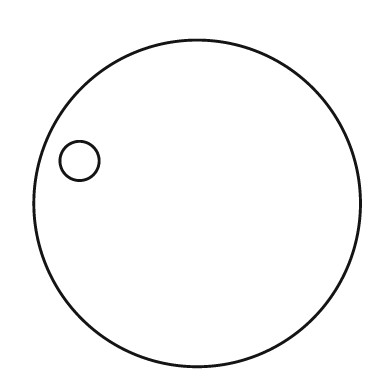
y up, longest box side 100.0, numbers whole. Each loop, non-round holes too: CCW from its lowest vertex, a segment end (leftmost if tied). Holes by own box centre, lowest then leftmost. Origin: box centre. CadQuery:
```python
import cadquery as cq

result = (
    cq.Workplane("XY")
    .moveTo(0.0, 0.0)
    .circle(50.0)
    .moveTo(-36.0, 13.0)
    .circle(6.0)
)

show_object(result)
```